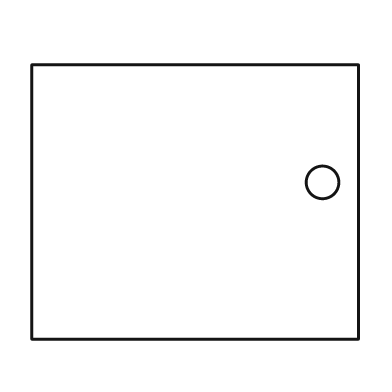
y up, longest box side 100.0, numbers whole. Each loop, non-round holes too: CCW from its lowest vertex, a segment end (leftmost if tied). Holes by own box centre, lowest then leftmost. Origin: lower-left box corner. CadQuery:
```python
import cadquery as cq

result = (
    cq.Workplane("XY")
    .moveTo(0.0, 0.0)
    .lineTo(100.0, 0.0)
    .lineTo(100.0, 84.0)
    .lineTo(0.0, 84.0)
    .close()
    .moveTo(89.0, 48.0)
    .circle(5.0)
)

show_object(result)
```